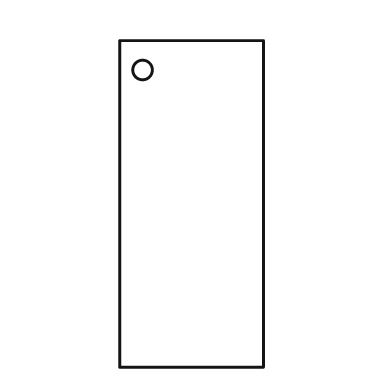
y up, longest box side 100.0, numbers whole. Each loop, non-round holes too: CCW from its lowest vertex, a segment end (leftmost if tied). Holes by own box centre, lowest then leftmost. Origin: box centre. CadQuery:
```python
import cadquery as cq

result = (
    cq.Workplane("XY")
    .moveTo(-22.0, -50.0)
    .lineTo(22.0, -50.0)
    .lineTo(22.0, 50.0)
    .lineTo(-22.0, 50.0)
    .close()
    .moveTo(-15.0, 41.0)
    .circle(3.0)
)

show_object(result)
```